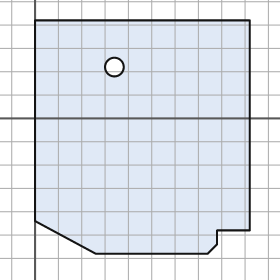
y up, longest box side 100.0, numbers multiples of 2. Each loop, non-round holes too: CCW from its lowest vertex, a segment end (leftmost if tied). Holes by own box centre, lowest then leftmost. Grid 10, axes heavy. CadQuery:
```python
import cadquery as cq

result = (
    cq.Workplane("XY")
    .moveTo(26.0, -58.0)
    .lineTo(74.0, -58.0)
    .lineTo(78.0, -54.0)
    .lineTo(78.0, -48.0)
    .lineTo(92.0, -48.0)
    .lineTo(92.0, 42.0)
    .lineTo(0.0, 42.0)
    .lineTo(0.0, -44.0)
    .close()
    .moveTo(34.0, 22.0)
    .circle(4.0)
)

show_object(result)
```